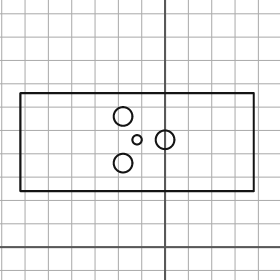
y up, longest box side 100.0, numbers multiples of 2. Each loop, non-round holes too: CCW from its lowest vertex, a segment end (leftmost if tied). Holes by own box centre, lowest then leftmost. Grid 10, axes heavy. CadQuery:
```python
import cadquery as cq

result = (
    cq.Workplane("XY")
    .moveTo(-62.0, 24.0)
    .lineTo(38.0, 24.0)
    .lineTo(38.0, 66.0)
    .lineTo(-62.0, 66.0)
    .close()
    .moveTo(-18.0, 36.0)
    .circle(4.0)
    .moveTo(-12.0, 46.0)
    .circle(2.0)
    .moveTo(0.0, 46.0)
    .circle(4.0)
    .moveTo(-18.0, 56.0)
    .circle(4.0)
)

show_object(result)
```